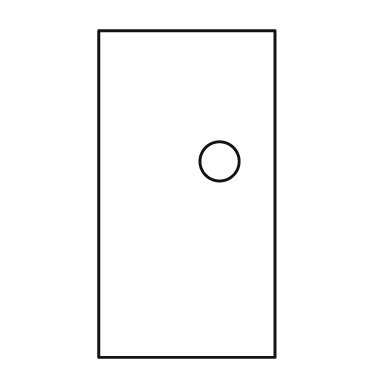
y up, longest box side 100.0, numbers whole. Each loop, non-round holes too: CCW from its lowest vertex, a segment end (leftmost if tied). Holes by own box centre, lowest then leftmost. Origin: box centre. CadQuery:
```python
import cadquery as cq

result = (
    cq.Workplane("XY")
    .moveTo(-27.0, -50.0)
    .lineTo(27.0, -50.0)
    .lineTo(27.0, 50.0)
    .lineTo(-27.0, 50.0)
    .close()
    .moveTo(10.0, 10.0)
    .circle(6.0)
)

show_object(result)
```